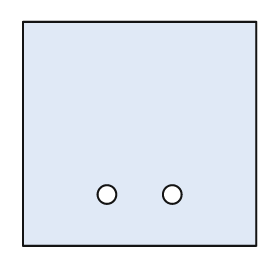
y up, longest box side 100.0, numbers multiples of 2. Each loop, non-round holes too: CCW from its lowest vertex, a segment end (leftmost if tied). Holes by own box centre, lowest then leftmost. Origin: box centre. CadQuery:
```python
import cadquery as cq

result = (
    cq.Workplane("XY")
    .moveTo(-50.0, -48.0)
    .lineTo(50.0, -48.0)
    .lineTo(50.0, 48.0)
    .lineTo(-50.0, 48.0)
    .close()
    .moveTo(-14.0, -26.0)
    .circle(4.0)
    .moveTo(14.0, -26.0)
    .circle(4.0)
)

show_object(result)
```